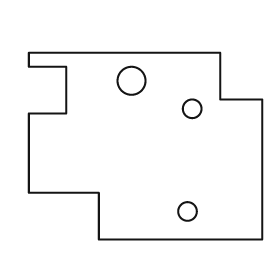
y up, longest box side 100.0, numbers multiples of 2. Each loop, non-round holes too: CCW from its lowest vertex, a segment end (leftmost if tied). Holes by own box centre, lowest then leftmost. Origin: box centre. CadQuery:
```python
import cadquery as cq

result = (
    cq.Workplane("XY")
    .moveTo(-20.0, -40.0)
    .lineTo(50.0, -40.0)
    .lineTo(50.0, 20.0)
    .lineTo(32.0, 20.0)
    .lineTo(32.0, 40.0)
    .lineTo(-50.0, 40.0)
    .lineTo(-50.0, 34.0)
    .lineTo(-34.0, 34.0)
    .lineTo(-34.0, 14.0)
    .lineTo(-50.0, 14.0)
    .lineTo(-50.0, -20.0)
    .lineTo(-20.0, -20.0)
    .close()
    .moveTo(18.0, -28.0)
    .circle(4.0)
    .moveTo(20.0, 16.0)
    .circle(4.0)
    .moveTo(-6.0, 28.0)
    .circle(6.0)
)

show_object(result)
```